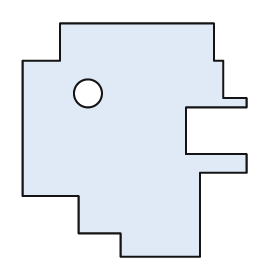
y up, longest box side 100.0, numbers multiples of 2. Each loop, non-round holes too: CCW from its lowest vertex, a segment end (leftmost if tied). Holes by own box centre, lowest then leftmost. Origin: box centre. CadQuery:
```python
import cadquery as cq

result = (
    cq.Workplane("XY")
    .moveTo(-6.0, -50.0)
    .lineTo(28.0, -50.0)
    .lineTo(28.0, -14.0)
    .lineTo(48.0, -14.0)
    .lineTo(48.0, -6.0)
    .lineTo(22.0, -6.0)
    .lineTo(22.0, 14.0)
    .lineTo(48.0, 14.0)
    .lineTo(48.0, 18.0)
    .lineTo(38.0, 18.0)
    .lineTo(38.0, 34.0)
    .lineTo(34.0, 34.0)
    .lineTo(34.0, 50.0)
    .lineTo(-32.0, 50.0)
    .lineTo(-32.0, 34.0)
    .lineTo(-48.0, 34.0)
    .lineTo(-48.0, -24.0)
    .lineTo(-24.0, -24.0)
    .lineTo(-24.0, -40.0)
    .lineTo(-6.0, -40.0)
    .close()
    .moveTo(-20.0, 20.0)
    .circle(6.0)
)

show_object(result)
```